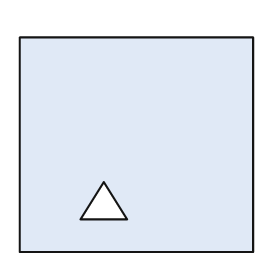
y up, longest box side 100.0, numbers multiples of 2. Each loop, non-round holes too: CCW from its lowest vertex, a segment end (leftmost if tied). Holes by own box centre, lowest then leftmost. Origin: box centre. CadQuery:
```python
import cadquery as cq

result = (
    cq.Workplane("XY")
    .moveTo(-50.0, -46.0)
    .lineTo(50.0, -46.0)
    .lineTo(50.0, 46.0)
    .lineTo(-50.0, 46.0)
    .close()
    .moveTo(-24.0, -32.0)
    .lineTo(-4.0, -32.0)
    .lineTo(-14.0, -16.0)
    .close()
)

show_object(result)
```